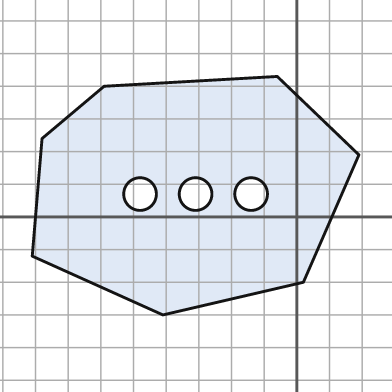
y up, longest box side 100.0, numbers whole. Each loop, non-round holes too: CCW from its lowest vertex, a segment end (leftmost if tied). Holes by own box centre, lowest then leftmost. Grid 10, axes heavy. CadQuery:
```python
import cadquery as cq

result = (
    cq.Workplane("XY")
    .moveTo(-41.0, -30.0)
    .lineTo(2.0, -20.0)
    .lineTo(19.0, 19.0)
    .lineTo(-6.0, 43.0)
    .lineTo(-59.0, 40.0)
    .lineTo(-78.0, 24.0)
    .lineTo(-81.0, -12.0)
    .close()
    .moveTo(-48.0, 7.0)
    .circle(5.0)
    .moveTo(-31.0, 7.0)
    .circle(5.0)
    .moveTo(-14.0, 7.0)
    .circle(5.0)
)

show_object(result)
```